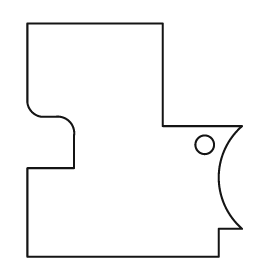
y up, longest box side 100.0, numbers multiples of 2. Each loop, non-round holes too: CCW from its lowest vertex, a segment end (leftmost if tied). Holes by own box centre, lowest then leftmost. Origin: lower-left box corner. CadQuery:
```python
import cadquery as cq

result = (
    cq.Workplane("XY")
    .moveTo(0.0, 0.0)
    .lineTo(82.0, 0.0)
    .lineTo(82.0, 12.0)
    .lineTo(92.0, 12.0)
    .threePointArc((82.0, 34.0), (92.0, 56.0))
    .lineTo(58.0, 56.0)
    .lineTo(58.0, 100.0)
    .lineTo(0.0, 100.0)
    .lineTo(0.0, 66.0)
    .threePointArc((2.0, 62.0), (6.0, 60.0))
    .lineTo(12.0, 60.0)
    .threePointArc((18.0, 58.0), (20.0, 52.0))
    .lineTo(20.0, 38.0)
    .lineTo(0.0, 38.0)
    .close()
    .moveTo(76.0, 48.0)
    .circle(4.0)
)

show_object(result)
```